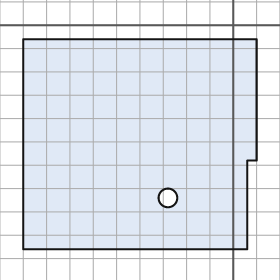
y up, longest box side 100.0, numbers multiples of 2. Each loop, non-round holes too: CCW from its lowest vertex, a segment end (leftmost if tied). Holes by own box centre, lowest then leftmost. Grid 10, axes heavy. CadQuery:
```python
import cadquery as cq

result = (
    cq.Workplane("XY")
    .moveTo(-90.0, -96.0)
    .lineTo(6.0, -96.0)
    .lineTo(6.0, -58.0)
    .lineTo(10.0, -58.0)
    .lineTo(10.0, -6.0)
    .lineTo(-90.0, -6.0)
    .close()
    .moveTo(-28.0, -74.0)
    .circle(4.0)
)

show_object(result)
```